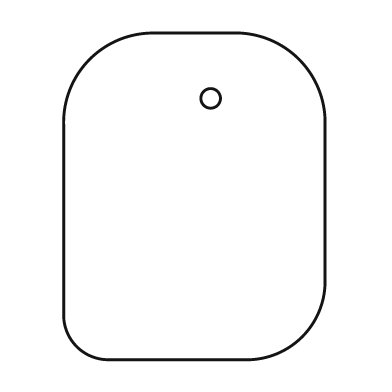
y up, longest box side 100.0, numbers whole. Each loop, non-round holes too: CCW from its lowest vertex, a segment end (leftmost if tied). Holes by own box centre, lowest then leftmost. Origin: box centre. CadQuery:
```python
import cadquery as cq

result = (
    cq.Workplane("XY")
    .moveTo(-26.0, -50.0)
    .lineTo(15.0, -50.0)
    .threePointArc((33.0, -43.0), (40.0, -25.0))
    .lineTo(40.0, 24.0)
    .threePointArc((32.0, 42.0), (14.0, 50.0))
    .lineTo(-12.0, 50.0)
    .threePointArc((-32.0, 42.0), (-40.0, 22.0))
    .lineTo(-40.0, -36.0)
    .threePointArc((-36.0, -46.0), (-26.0, -50.0))
    .close()
    .moveTo(5.0, 30.0)
    .circle(3.0)
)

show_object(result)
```